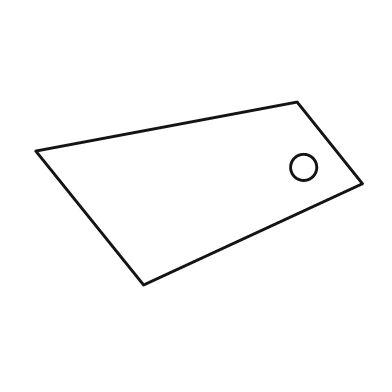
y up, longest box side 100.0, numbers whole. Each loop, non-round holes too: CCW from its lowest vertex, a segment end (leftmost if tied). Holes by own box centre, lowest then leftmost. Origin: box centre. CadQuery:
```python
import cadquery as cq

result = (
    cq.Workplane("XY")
    .moveTo(-17.0, -28.0)
    .lineTo(50.0, 3.0)
    .lineTo(30.0, 28.0)
    .lineTo(-50.0, 13.0)
    .close()
    .moveTo(32.0, 8.0)
    .circle(4.0)
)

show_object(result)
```